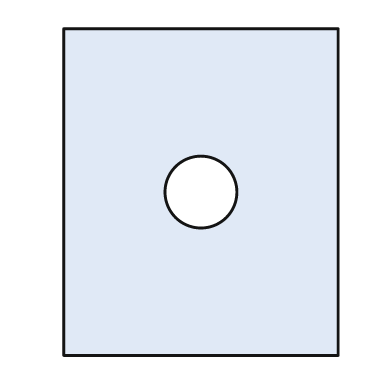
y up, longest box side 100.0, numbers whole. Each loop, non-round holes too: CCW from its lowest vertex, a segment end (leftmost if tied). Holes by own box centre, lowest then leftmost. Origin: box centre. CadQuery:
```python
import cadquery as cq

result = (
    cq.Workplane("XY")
    .moveTo(-42.0, -50.0)
    .lineTo(42.0, -50.0)
    .lineTo(42.0, 50.0)
    .lineTo(-42.0, 50.0)
    .close()
    .moveTo(0.0, 0.0)
    .circle(11.0)
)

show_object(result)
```